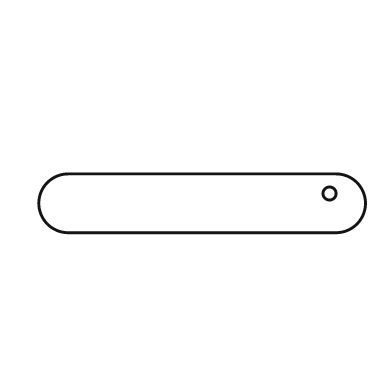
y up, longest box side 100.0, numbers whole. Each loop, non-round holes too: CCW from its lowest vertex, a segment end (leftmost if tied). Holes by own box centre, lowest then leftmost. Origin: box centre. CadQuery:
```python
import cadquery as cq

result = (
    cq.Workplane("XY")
    .moveTo(-41.0, -9.0)
    .lineTo(41.0, -9.0)
    .threePointArc((50.0, 0.0), (41.0, 9.0))
    .lineTo(-41.0, 9.0)
    .threePointArc((-50.0, 0.0), (-41.0, -9.0))
    .close()
    .moveTo(39.0, 3.0)
    .circle(2.0)
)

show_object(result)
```